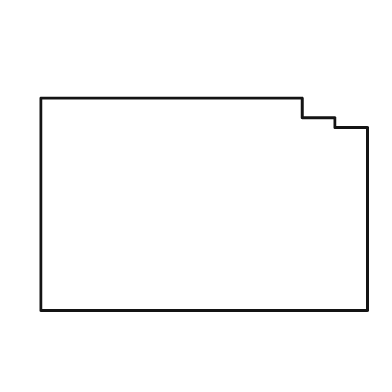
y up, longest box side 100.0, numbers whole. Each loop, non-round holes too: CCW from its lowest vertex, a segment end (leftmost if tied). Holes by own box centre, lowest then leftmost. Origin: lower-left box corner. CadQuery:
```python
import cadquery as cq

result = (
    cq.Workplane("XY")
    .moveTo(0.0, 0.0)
    .lineTo(100.0, 0.0)
    .lineTo(100.0, 56.0)
    .lineTo(90.0, 56.0)
    .lineTo(90.0, 59.0)
    .lineTo(80.0, 59.0)
    .lineTo(80.0, 65.0)
    .lineTo(0.0, 65.0)
    .close()
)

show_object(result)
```